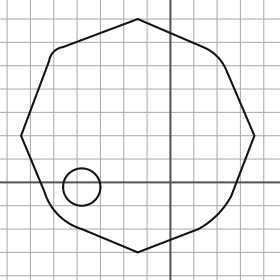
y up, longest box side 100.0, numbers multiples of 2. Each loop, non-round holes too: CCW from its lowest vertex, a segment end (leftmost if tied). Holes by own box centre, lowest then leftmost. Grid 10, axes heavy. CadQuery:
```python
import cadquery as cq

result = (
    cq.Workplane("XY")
    .moveTo(-14.0, -30.0)
    .lineTo(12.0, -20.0)
    .threePointArc((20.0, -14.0), (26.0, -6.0))
    .lineTo(36.0, 20.0)
    .lineTo(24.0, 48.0)
    .threePointArc((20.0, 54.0), (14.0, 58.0))
    .lineTo(-14.0, 70.0)
    .lineTo(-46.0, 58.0)
    .threePointArc((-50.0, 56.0), (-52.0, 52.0))
    .lineTo(-64.0, 20.0)
    .lineTo(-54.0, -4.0)
    .threePointArc((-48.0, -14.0), (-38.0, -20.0))
    .close()
    .moveTo(-38.0, -2.0)
    .circle(8.0)
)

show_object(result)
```